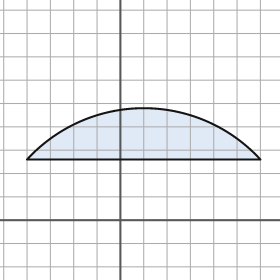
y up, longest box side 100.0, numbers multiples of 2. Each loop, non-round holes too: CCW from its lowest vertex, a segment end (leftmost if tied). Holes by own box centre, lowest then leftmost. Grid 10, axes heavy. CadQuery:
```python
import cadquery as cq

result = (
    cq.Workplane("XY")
    .moveTo(-40.0, 26.0)
    .lineTo(60.0, 26.0)
    .threePointArc((10.0, 48.0), (-40.0, 26.0))
    .close()
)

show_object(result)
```